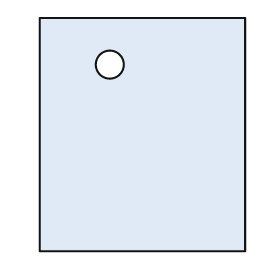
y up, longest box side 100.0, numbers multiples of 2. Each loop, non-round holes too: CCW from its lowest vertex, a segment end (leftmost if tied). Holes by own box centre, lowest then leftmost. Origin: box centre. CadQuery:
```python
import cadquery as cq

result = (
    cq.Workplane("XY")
    .moveTo(-44.0, -50.0)
    .lineTo(44.0, -50.0)
    .lineTo(44.0, 50.0)
    .lineTo(-44.0, 50.0)
    .close()
    .moveTo(-14.0, 30.0)
    .circle(6.0)
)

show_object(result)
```